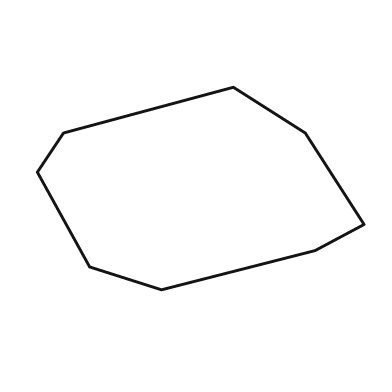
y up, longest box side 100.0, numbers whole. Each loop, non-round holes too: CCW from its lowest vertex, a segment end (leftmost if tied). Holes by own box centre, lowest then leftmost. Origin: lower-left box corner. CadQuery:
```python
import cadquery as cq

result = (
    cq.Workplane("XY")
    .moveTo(38.0, 0.0)
    .lineTo(85.0, 12.0)
    .lineTo(100.0, 20.0)
    .lineTo(82.0, 48.0)
    .lineTo(60.0, 62.0)
    .lineTo(8.0, 48.0)
    .lineTo(0.0, 36.0)
    .lineTo(16.0, 7.0)
    .close()
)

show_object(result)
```